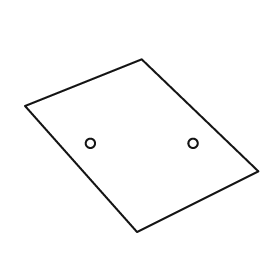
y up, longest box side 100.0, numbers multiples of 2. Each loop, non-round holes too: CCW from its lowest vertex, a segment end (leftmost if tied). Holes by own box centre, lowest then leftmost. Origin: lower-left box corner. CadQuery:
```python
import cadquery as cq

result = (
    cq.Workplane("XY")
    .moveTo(48.0, 0.0)
    .lineTo(100.0, 26.0)
    .lineTo(50.0, 74.0)
    .lineTo(0.0, 54.0)
    .close()
    .moveTo(28.0, 38.0)
    .circle(2.0)
    .moveTo(72.0, 38.0)
    .circle(2.0)
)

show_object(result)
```